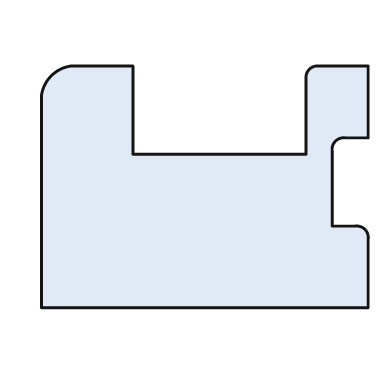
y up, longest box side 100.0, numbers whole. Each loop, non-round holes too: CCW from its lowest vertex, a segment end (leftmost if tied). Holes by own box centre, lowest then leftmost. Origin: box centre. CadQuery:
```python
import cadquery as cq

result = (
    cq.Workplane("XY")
    .moveTo(-50.0, -37.0)
    .lineTo(50.0, -37.0)
    .lineTo(50.0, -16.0)
    .threePointArc((49.0, -13.0), (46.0, -12.0))
    .lineTo(39.0, -12.0)
    .lineTo(39.0, 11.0)
    .threePointArc((40.0, 14.0), (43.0, 15.0))
    .lineTo(50.0, 15.0)
    .lineTo(50.0, 37.0)
    .lineTo(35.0, 37.0)
    .threePointArc((32.0, 36.0), (31.0, 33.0))
    .lineTo(31.0, 10.0)
    .lineTo(-22.0, 10.0)
    .lineTo(-22.0, 37.0)
    .lineTo(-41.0, 37.0)
    .threePointArc((-47.0, 34.0), (-50.0, 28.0))
    .close()
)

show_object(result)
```